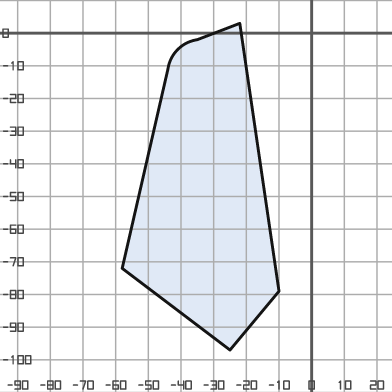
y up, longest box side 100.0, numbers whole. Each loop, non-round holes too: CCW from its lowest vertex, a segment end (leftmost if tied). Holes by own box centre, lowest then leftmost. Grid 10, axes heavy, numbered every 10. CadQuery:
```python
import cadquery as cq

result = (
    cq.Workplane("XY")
    .moveTo(-25.0, -97.0)
    .lineTo(-10.0, -79.0)
    .lineTo(-22.0, 3.0)
    .lineTo(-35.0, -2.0)
    .threePointArc((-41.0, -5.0), (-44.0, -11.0))
    .lineTo(-58.0, -72.0)
    .close()
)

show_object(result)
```